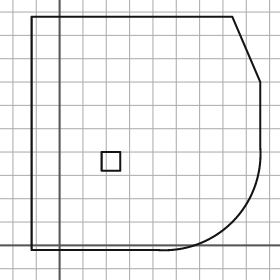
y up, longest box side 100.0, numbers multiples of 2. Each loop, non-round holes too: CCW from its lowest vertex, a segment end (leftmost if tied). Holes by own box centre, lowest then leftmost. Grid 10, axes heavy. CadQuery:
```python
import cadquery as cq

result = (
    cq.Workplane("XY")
    .moveTo(-12.0, -2.0)
    .lineTo(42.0, -2.0)
    .threePointArc((74.0, 10.0), (86.0, 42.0))
    .lineTo(86.0, 70.0)
    .lineTo(74.0, 98.0)
    .lineTo(-12.0, 98.0)
    .close()
    .moveTo(18.0, 32.0)
    .lineTo(26.0, 32.0)
    .lineTo(26.0, 40.0)
    .lineTo(18.0, 40.0)
    .close()
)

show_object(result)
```